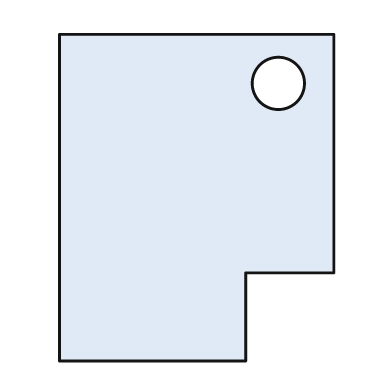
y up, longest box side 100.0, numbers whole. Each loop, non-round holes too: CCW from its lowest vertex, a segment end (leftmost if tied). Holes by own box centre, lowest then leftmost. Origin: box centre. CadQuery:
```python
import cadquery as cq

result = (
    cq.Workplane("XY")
    .moveTo(-42.0, -50.0)
    .lineTo(15.0, -50.0)
    .lineTo(15.0, -23.0)
    .lineTo(42.0, -23.0)
    .lineTo(42.0, 50.0)
    .lineTo(-42.0, 50.0)
    .close()
    .moveTo(25.0, 35.0)
    .circle(8.0)
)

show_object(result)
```